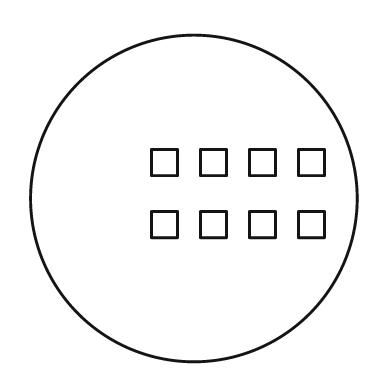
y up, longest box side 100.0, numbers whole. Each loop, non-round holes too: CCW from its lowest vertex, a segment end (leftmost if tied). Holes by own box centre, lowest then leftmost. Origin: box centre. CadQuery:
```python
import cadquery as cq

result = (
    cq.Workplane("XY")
    .moveTo(0.0, 0.0)
    .circle(50.0)
    .moveTo(-13.0, -12.0)
    .lineTo(-5.0, -12.0)
    .lineTo(-5.0, -4.0)
    .lineTo(-13.0, -4.0)
    .close()
    .moveTo(2.0, -12.0)
    .lineTo(10.0, -12.0)
    .lineTo(10.0, -4.0)
    .lineTo(2.0, -4.0)
    .close()
    .moveTo(17.0, -12.0)
    .lineTo(25.0, -12.0)
    .lineTo(25.0, -4.0)
    .lineTo(17.0, -4.0)
    .close()
    .moveTo(32.0, -12.0)
    .lineTo(40.0, -12.0)
    .lineTo(40.0, -4.0)
    .lineTo(32.0, -4.0)
    .close()
    .moveTo(-13.0, 7.0)
    .lineTo(-5.0, 7.0)
    .lineTo(-5.0, 15.0)
    .lineTo(-13.0, 15.0)
    .close()
    .moveTo(2.0, 7.0)
    .lineTo(10.0, 7.0)
    .lineTo(10.0, 15.0)
    .lineTo(2.0, 15.0)
    .close()
    .moveTo(17.0, 7.0)
    .lineTo(25.0, 7.0)
    .lineTo(25.0, 15.0)
    .lineTo(17.0, 15.0)
    .close()
    .moveTo(32.0, 7.0)
    .lineTo(40.0, 7.0)
    .lineTo(40.0, 15.0)
    .lineTo(32.0, 15.0)
    .close()
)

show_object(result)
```